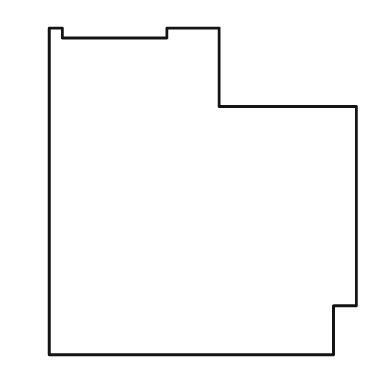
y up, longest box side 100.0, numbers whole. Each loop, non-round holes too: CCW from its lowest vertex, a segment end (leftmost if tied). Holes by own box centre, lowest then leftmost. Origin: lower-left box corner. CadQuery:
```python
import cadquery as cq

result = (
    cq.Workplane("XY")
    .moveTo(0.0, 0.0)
    .lineTo(87.0, 0.0)
    .lineTo(87.0, 15.0)
    .lineTo(94.0, 15.0)
    .lineTo(94.0, 76.0)
    .lineTo(52.0, 76.0)
    .lineTo(52.0, 100.0)
    .lineTo(36.0, 100.0)
    .lineTo(36.0, 97.0)
    .lineTo(4.0, 97.0)
    .lineTo(4.0, 100.0)
    .lineTo(0.0, 100.0)
    .close()
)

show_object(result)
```